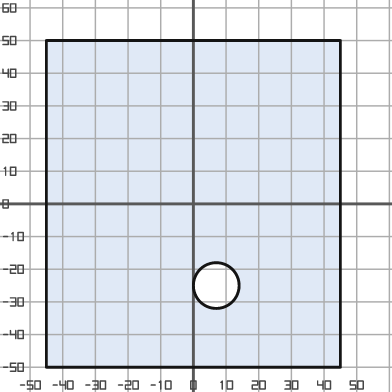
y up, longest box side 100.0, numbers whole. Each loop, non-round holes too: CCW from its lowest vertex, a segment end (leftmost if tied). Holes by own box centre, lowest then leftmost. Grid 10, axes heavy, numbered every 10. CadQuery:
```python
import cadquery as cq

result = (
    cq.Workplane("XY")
    .moveTo(-45.0, -50.0)
    .lineTo(45.0, -50.0)
    .lineTo(45.0, 50.0)
    .lineTo(-45.0, 50.0)
    .close()
    .moveTo(7.0, -25.0)
    .circle(7.0)
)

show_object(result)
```